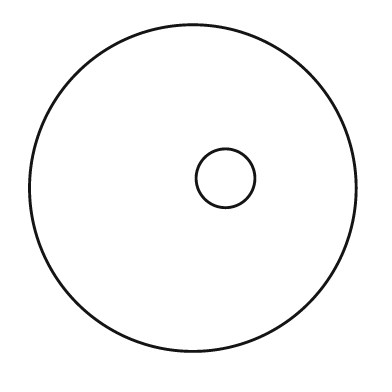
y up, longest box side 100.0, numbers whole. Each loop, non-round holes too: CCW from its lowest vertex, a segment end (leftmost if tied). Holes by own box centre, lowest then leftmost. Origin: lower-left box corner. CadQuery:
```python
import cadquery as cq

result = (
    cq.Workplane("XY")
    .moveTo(50.0, 50.0)
    .circle(50.0)
    .moveTo(60.0, 53.0)
    .circle(9.0)
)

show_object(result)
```